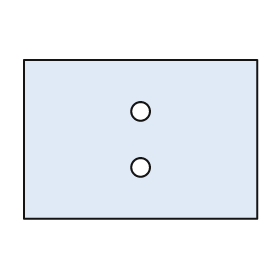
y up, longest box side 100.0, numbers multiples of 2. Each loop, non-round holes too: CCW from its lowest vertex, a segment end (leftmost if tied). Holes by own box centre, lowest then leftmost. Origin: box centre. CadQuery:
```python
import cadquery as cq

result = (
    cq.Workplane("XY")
    .moveTo(-50.0, -34.0)
    .lineTo(50.0, -34.0)
    .lineTo(50.0, 34.0)
    .lineTo(-50.0, 34.0)
    .close()
    .moveTo(0.0, -12.0)
    .circle(4.0)
    .moveTo(0.0, 12.0)
    .circle(4.0)
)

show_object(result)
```